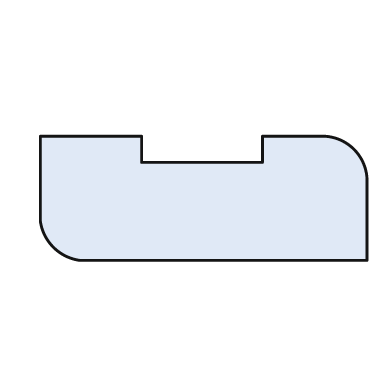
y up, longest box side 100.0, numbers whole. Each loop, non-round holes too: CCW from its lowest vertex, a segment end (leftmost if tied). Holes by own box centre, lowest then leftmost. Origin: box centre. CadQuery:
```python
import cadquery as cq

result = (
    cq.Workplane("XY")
    .moveTo(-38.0, -19.0)
    .lineTo(50.0, -19.0)
    .lineTo(50.0, 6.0)
    .threePointArc((46.0, 15.0), (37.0, 19.0))
    .lineTo(18.0, 19.0)
    .lineTo(18.0, 11.0)
    .lineTo(-19.0, 11.0)
    .lineTo(-19.0, 19.0)
    .lineTo(-50.0, 19.0)
    .lineTo(-50.0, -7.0)
    .threePointArc((-46.0, -15.0), (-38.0, -19.0))
    .close()
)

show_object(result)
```